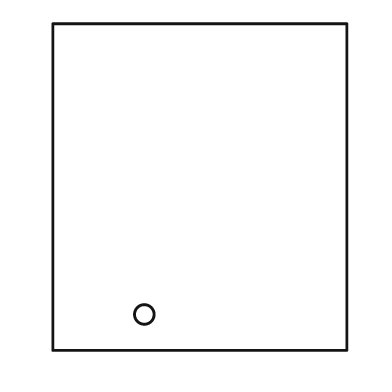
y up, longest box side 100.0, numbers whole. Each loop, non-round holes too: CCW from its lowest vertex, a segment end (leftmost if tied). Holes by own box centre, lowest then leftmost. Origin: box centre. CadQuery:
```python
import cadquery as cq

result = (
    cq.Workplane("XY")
    .moveTo(-45.0, -50.0)
    .lineTo(45.0, -50.0)
    .lineTo(45.0, 50.0)
    .lineTo(-45.0, 50.0)
    .close()
    .moveTo(-17.0, -39.0)
    .circle(3.0)
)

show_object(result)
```